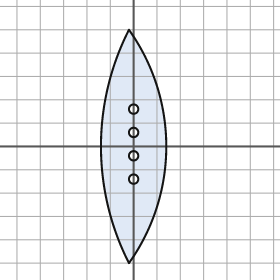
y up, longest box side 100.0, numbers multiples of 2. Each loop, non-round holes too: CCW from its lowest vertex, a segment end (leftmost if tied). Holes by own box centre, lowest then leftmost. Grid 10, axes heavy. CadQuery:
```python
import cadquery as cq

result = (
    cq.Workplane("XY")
    .moveTo(-2.0, -50.0)
    .threePointArc((14.0, 0.0), (-2.0, 50.0))
    .threePointArc((-14.0, 0.0), (-2.0, -50.0))
    .close()
    .moveTo(0.0, -14.0)
    .circle(2.0)
    .moveTo(0.0, -4.0)
    .circle(2.0)
    .moveTo(0.0, 6.0)
    .circle(2.0)
    .moveTo(0.0, 16.0)
    .circle(2.0)
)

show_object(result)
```